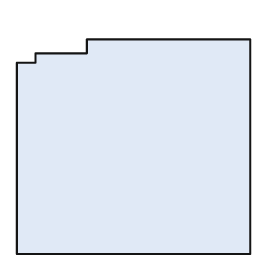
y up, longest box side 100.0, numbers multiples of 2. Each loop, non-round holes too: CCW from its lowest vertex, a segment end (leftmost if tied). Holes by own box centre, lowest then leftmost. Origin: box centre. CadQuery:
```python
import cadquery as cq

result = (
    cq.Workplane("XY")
    .moveTo(-50.0, -46.0)
    .lineTo(50.0, -46.0)
    .lineTo(50.0, 46.0)
    .lineTo(-20.0, 46.0)
    .lineTo(-20.0, 40.0)
    .lineTo(-42.0, 40.0)
    .lineTo(-42.0, 36.0)
    .lineTo(-50.0, 36.0)
    .close()
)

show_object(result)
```